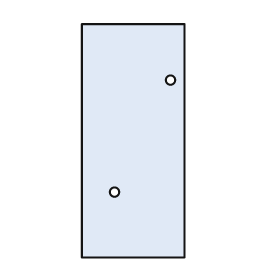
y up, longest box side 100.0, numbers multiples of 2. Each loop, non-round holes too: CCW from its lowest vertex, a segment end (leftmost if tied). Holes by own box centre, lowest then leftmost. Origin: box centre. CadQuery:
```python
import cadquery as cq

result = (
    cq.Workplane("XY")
    .moveTo(-22.0, -50.0)
    .lineTo(22.0, -50.0)
    .lineTo(22.0, 50.0)
    .lineTo(-22.0, 50.0)
    .close()
    .moveTo(-8.0, -22.0)
    .circle(2.0)
    .moveTo(16.0, 26.0)
    .circle(2.0)
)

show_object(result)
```